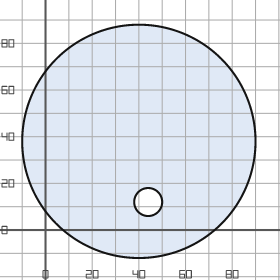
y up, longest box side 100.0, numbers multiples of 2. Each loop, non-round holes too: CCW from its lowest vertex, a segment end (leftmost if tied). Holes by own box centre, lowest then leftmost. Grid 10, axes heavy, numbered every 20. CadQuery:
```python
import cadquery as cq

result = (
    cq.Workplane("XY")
    .moveTo(40.0, 38.0)
    .circle(50.0)
    .moveTo(44.0, 12.0)
    .circle(6.0)
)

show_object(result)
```